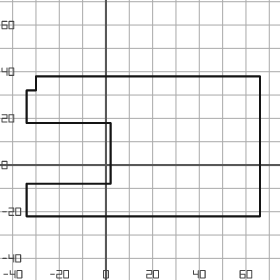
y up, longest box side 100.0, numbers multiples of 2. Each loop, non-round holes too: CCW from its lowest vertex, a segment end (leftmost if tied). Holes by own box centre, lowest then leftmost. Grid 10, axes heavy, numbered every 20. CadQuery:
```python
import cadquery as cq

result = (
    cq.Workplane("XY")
    .moveTo(-34.0, -22.0)
    .lineTo(66.0, -22.0)
    .lineTo(66.0, 38.0)
    .lineTo(-30.0, 38.0)
    .lineTo(-30.0, 32.0)
    .lineTo(-34.0, 32.0)
    .lineTo(-34.0, 18.0)
    .lineTo(2.0, 18.0)
    .lineTo(2.0, -8.0)
    .lineTo(-34.0, -8.0)
    .close()
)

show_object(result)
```